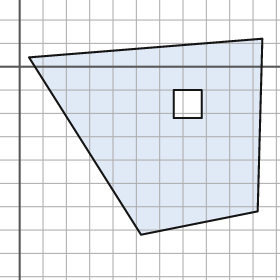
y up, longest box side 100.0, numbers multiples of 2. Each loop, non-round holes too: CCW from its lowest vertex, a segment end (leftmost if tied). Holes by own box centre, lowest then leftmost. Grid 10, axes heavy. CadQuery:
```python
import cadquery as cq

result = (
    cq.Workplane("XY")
    .moveTo(52.0, -72.0)
    .lineTo(102.0, -62.0)
    .lineTo(104.0, 12.0)
    .lineTo(4.0, 4.0)
    .close()
    .moveTo(66.0, -22.0)
    .lineTo(78.0, -22.0)
    .lineTo(78.0, -10.0)
    .lineTo(66.0, -10.0)
    .close()
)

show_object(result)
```